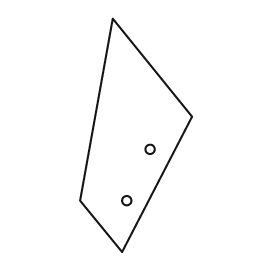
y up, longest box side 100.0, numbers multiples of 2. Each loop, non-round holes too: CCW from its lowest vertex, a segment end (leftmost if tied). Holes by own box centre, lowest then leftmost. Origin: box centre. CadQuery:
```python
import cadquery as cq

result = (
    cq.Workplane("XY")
    .moveTo(-6.0, -50.0)
    .lineTo(24.0, 8.0)
    .lineTo(-10.0, 50.0)
    .lineTo(-24.0, -28.0)
    .close()
    .moveTo(-4.0, -28.0)
    .circle(2.0)
    .moveTo(6.0, -6.0)
    .circle(2.0)
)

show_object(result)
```